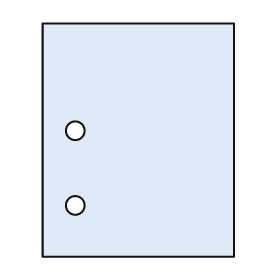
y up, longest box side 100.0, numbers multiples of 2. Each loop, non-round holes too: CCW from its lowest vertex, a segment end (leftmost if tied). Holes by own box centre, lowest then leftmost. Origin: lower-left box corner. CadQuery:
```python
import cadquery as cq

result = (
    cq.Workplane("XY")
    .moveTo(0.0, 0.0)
    .lineTo(82.0, 0.0)
    .lineTo(82.0, 100.0)
    .lineTo(0.0, 100.0)
    .close()
    .moveTo(14.0, 22.0)
    .circle(4.0)
    .moveTo(14.0, 54.0)
    .circle(4.0)
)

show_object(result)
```